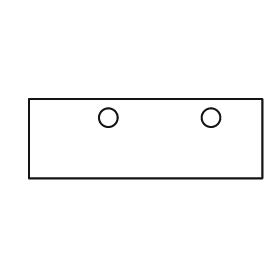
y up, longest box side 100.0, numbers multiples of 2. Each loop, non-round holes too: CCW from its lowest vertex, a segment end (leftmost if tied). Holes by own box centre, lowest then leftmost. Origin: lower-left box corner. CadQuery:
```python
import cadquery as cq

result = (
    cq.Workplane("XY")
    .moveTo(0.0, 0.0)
    .lineTo(100.0, 0.0)
    .lineTo(100.0, 34.0)
    .lineTo(0.0, 34.0)
    .close()
    .moveTo(34.0, 26.0)
    .circle(4.0)
    .moveTo(78.0, 26.0)
    .circle(4.0)
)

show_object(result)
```